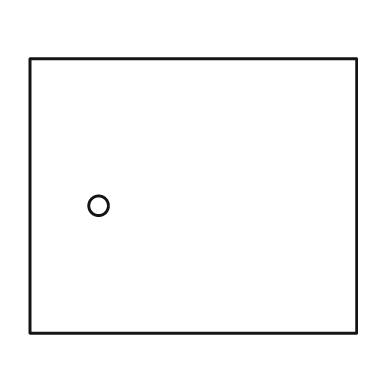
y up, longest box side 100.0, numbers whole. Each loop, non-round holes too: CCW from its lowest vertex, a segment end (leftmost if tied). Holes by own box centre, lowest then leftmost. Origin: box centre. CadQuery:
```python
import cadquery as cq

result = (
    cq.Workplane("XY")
    .moveTo(-50.0, -42.0)
    .lineTo(50.0, -42.0)
    .lineTo(50.0, 42.0)
    .lineTo(-50.0, 42.0)
    .close()
    .moveTo(-29.0, -3.0)
    .circle(3.0)
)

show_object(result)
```